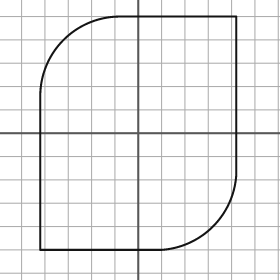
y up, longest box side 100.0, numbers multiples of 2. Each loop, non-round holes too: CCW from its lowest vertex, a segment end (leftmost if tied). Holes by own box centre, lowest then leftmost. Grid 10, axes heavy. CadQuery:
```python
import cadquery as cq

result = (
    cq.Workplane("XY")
    .moveTo(-42.0, -50.0)
    .lineTo(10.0, -50.0)
    .threePointArc((32.0, -40.0), (42.0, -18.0))
    .lineTo(42.0, 50.0)
    .lineTo(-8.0, 50.0)
    .threePointArc((-32.0, 40.0), (-42.0, 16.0))
    .close()
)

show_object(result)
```